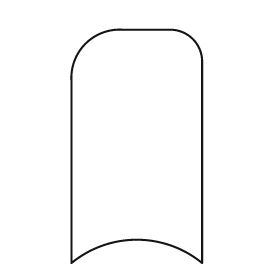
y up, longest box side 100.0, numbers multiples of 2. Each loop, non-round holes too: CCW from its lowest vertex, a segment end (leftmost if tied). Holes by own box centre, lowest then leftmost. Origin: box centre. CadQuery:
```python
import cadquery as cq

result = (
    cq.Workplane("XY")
    .moveTo(-28.0, -50.0)
    .threePointArc((0.0, -40.0), (28.0, -50.0))
    .lineTo(28.0, 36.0)
    .threePointArc((24.0, 46.0), (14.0, 50.0))
    .lineTo(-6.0, 50.0)
    .threePointArc((-22.0, 44.0), (-28.0, 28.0))
    .close()
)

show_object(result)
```